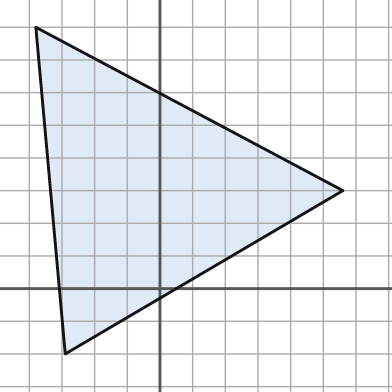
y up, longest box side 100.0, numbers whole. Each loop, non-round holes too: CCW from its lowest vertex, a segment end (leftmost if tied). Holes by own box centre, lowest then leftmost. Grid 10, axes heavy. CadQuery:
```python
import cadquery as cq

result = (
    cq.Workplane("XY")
    .moveTo(-29.0, -20.0)
    .lineTo(56.0, 30.0)
    .lineTo(-38.0, 80.0)
    .close()
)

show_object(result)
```